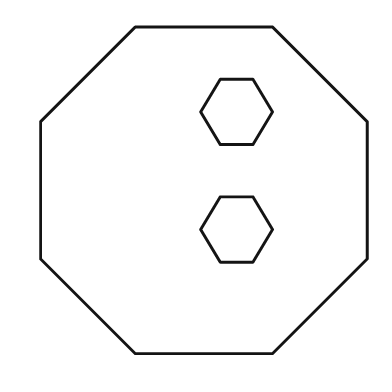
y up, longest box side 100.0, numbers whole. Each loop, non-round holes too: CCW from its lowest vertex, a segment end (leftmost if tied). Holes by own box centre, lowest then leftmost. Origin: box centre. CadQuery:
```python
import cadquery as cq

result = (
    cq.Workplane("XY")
    .moveTo(-21.0, -50.0)
    .lineTo(21.0, -50.0)
    .lineTo(50.0, -21.0)
    .lineTo(50.0, 21.0)
    .lineTo(21.0, 50.0)
    .lineTo(-21.0, 50.0)
    .lineTo(-50.0, 21.0)
    .lineTo(-50.0, -21.0)
    .close()
    .moveTo(5.0, -22.0)
    .lineTo(15.0, -22.0)
    .lineTo(21.0, -12.0)
    .lineTo(15.0, -2.0)
    .lineTo(5.0, -2.0)
    .lineTo(-1.0, -12.0)
    .close()
    .moveTo(5.0, 14.0)
    .lineTo(15.0, 14.0)
    .lineTo(21.0, 24.0)
    .lineTo(15.0, 34.0)
    .lineTo(5.0, 34.0)
    .lineTo(-1.0, 24.0)
    .close()
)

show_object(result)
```